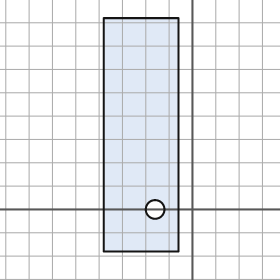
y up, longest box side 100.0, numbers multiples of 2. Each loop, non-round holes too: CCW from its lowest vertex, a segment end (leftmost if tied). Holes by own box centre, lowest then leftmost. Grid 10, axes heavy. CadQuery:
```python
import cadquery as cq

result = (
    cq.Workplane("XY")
    .moveTo(-38.0, -18.0)
    .lineTo(-6.0, -18.0)
    .lineTo(-6.0, 82.0)
    .lineTo(-38.0, 82.0)
    .close()
    .moveTo(-16.0, 0.0)
    .circle(4.0)
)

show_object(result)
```